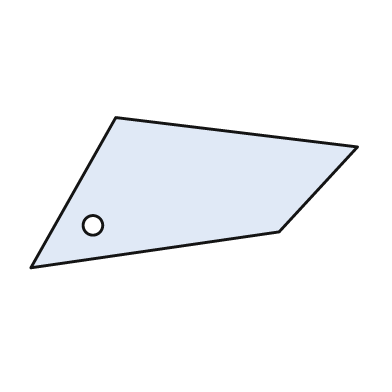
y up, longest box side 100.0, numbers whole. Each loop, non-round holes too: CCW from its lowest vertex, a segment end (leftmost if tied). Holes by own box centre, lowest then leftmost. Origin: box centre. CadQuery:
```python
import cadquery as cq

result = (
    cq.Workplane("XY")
    .moveTo(-50.0, -23.0)
    .lineTo(26.0, -12.0)
    .lineTo(50.0, 14.0)
    .lineTo(-24.0, 23.0)
    .close()
    .moveTo(-31.0, -10.0)
    .circle(3.0)
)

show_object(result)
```